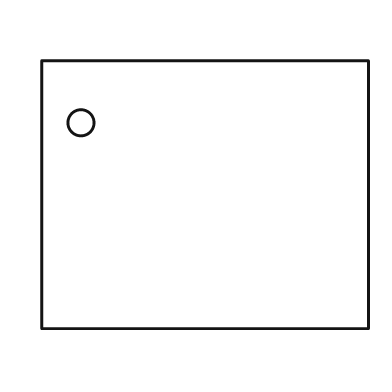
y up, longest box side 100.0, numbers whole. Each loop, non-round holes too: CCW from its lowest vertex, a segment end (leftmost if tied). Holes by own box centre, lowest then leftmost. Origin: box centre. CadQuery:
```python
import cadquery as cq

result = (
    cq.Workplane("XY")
    .moveTo(-50.0, -41.0)
    .lineTo(50.0, -41.0)
    .lineTo(50.0, 41.0)
    .lineTo(-50.0, 41.0)
    .close()
    .moveTo(-38.0, 22.0)
    .circle(4.0)
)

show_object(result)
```